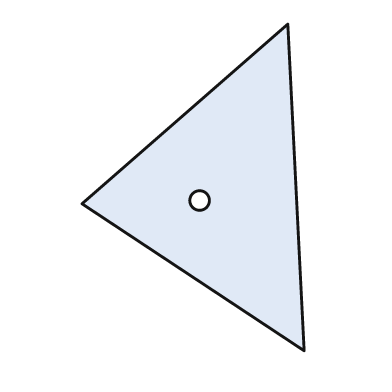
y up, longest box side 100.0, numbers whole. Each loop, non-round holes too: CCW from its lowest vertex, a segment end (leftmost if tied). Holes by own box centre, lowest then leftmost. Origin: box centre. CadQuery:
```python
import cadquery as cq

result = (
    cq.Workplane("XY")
    .moveTo(34.0, -50.0)
    .lineTo(29.0, 50.0)
    .lineTo(-34.0, -5.0)
    .close()
    .moveTo(2.0, -4.0)
    .circle(3.0)
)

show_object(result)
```